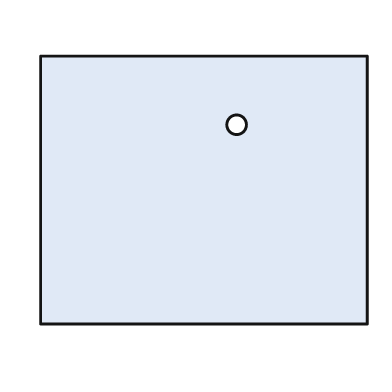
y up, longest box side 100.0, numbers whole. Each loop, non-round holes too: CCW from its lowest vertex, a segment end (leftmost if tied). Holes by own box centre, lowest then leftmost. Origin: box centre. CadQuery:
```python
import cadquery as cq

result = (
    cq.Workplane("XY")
    .moveTo(-50.0, -41.0)
    .lineTo(50.0, -41.0)
    .lineTo(50.0, 41.0)
    .lineTo(-50.0, 41.0)
    .close()
    .moveTo(10.0, 20.0)
    .circle(3.0)
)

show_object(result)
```